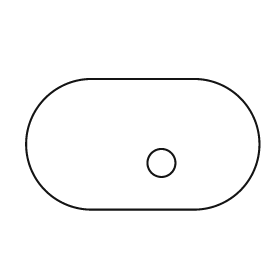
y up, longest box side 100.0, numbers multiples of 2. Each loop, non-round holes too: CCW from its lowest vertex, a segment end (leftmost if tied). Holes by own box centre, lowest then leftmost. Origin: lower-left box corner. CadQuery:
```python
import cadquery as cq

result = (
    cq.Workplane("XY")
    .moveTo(28.0, 0.0)
    .lineTo(72.0, 0.0)
    .threePointArc((100.0, 28.0), (72.0, 56.0))
    .lineTo(28.0, 56.0)
    .threePointArc((0.0, 28.0), (28.0, 0.0))
    .close()
    .moveTo(58.0, 20.0)
    .circle(6.0)
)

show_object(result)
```